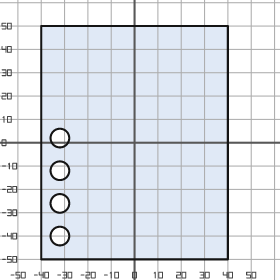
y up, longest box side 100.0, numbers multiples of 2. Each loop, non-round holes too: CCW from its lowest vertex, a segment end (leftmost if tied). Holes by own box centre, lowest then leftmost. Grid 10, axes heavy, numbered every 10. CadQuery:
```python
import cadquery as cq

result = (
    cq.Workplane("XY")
    .moveTo(-40.0, -50.0)
    .lineTo(40.0, -50.0)
    .lineTo(40.0, 50.0)
    .lineTo(-40.0, 50.0)
    .close()
    .moveTo(-32.0, -40.0)
    .circle(4.0)
    .moveTo(-32.0, -26.0)
    .circle(4.0)
    .moveTo(-32.0, -12.0)
    .circle(4.0)
    .moveTo(-32.0, 2.0)
    .circle(4.0)
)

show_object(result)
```